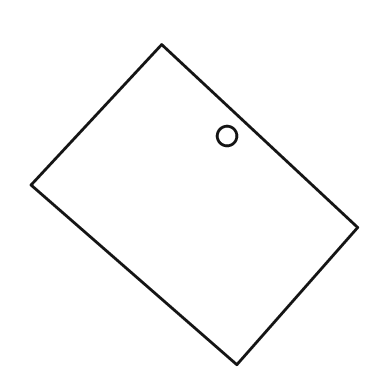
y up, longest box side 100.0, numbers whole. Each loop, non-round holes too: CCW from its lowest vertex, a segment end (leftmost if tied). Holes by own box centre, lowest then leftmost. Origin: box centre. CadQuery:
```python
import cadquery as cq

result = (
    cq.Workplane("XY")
    .moveTo(13.0, -49.0)
    .lineTo(50.0, -7.0)
    .lineTo(-10.0, 49.0)
    .lineTo(-50.0, 6.0)
    .close()
    .moveTo(10.0, 21.0)
    .circle(3.0)
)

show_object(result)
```